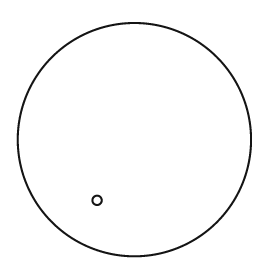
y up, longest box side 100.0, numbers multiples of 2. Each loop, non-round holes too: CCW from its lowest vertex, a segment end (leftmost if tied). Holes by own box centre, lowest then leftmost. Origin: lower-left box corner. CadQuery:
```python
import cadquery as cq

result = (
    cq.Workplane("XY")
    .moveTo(50.0, 50.0)
    .circle(50.0)
    .moveTo(34.0, 24.0)
    .circle(2.0)
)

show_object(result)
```